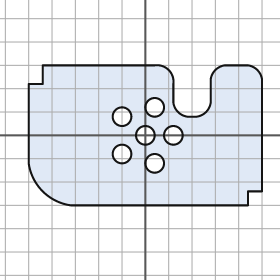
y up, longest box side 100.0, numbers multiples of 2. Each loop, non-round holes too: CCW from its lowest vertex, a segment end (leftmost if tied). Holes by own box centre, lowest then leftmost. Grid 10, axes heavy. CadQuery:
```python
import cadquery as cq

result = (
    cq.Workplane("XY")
    .moveTo(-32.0, -30.0)
    .lineTo(44.0, -30.0)
    .lineTo(44.0, -24.0)
    .lineTo(50.0, -24.0)
    .lineTo(50.0, 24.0)
    .threePointArc((48.0, 28.0), (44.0, 30.0))
    .lineTo(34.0, 30.0)
    .threePointArc((30.0, 28.0), (28.0, 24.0))
    .lineTo(28.0, 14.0)
    .threePointArc((26.0, 10.0), (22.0, 8.0))
    .lineTo(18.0, 8.0)
    .threePointArc((14.0, 10.0), (12.0, 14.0))
    .lineTo(12.0, 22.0)
    .threePointArc((10.0, 28.0), (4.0, 30.0))
    .lineTo(-44.0, 30.0)
    .lineTo(-44.0, 22.0)
    .lineTo(-50.0, 22.0)
    .lineTo(-50.0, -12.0)
    .threePointArc((-44.0, -24.0), (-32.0, -30.0))
    .close()
    .moveTo(4.0, -12.0)
    .circle(4.0)
    .moveTo(-10.0, -8.0)
    .circle(4.0)
    .moveTo(0.0, 0.0)
    .circle(4.0)
    .moveTo(12.0, 0.0)
    .circle(4.0)
    .moveTo(-10.0, 8.0)
    .circle(4.0)
    .moveTo(4.0, 12.0)
    .circle(4.0)
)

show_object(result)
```